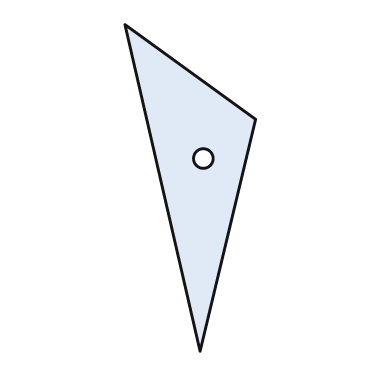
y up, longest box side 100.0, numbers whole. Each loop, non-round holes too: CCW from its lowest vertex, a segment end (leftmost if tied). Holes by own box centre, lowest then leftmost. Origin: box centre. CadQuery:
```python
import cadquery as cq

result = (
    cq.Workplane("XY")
    .moveTo(3.0, -50.0)
    .lineTo(20.0, 21.0)
    .lineTo(-20.0, 50.0)
    .close()
    .moveTo(4.0, 9.0)
    .circle(3.0)
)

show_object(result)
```